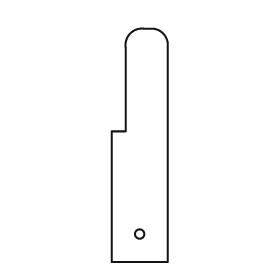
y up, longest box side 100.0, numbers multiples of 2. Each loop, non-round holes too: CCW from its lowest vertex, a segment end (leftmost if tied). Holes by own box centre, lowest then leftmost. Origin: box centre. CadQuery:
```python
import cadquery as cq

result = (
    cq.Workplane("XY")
    .moveTo(-12.0, -50.0)
    .lineTo(12.0, -50.0)
    .lineTo(12.0, 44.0)
    .threePointArc((10.0, 48.0), (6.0, 50.0))
    .lineTo(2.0, 50.0)
    .threePointArc((-4.0, 48.0), (-6.0, 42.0))
    .lineTo(-6.0, 6.0)
    .lineTo(-12.0, 6.0)
    .close()
    .moveTo(0.0, -38.0)
    .circle(2.0)
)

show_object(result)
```